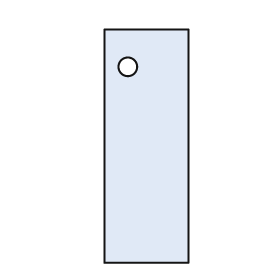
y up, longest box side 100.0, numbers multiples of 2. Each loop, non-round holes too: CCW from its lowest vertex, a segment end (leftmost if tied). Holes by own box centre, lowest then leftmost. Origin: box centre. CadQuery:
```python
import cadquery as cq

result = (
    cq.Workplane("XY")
    .moveTo(-18.0, -50.0)
    .lineTo(18.0, -50.0)
    .lineTo(18.0, 50.0)
    .lineTo(-18.0, 50.0)
    .close()
    .moveTo(-8.0, 34.0)
    .circle(4.0)
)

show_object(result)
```